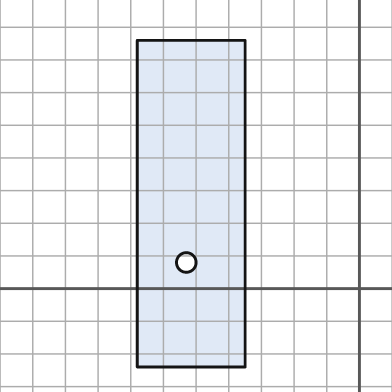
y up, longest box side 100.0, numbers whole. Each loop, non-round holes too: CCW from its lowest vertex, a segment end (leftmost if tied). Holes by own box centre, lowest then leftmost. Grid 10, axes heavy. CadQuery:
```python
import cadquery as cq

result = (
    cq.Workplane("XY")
    .moveTo(-68.0, -24.0)
    .lineTo(-35.0, -24.0)
    .lineTo(-35.0, 76.0)
    .lineTo(-68.0, 76.0)
    .close()
    .moveTo(-53.0, 8.0)
    .circle(3.0)
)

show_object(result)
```